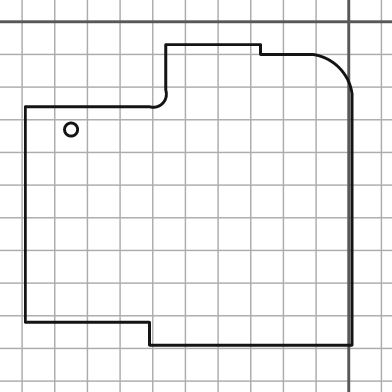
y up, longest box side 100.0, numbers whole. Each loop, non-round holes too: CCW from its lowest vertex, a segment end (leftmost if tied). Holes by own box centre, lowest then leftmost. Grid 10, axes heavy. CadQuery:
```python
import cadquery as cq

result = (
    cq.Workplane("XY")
    .moveTo(-61.0, -99.0)
    .lineTo(1.0, -99.0)
    .lineTo(1.0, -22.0)
    .threePointArc((-3.0, -14.0), (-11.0, -10.0))
    .lineTo(-27.0, -10.0)
    .lineTo(-27.0, -7.0)
    .lineTo(-56.0, -7.0)
    .lineTo(-56.0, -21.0)
    .threePointArc((-57.0, -25.0), (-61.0, -26.0))
    .lineTo(-99.0, -26.0)
    .lineTo(-99.0, -92.0)
    .lineTo(-61.0, -92.0)
    .close()
    .moveTo(-85.0, -33.0)
    .circle(2.0)
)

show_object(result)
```